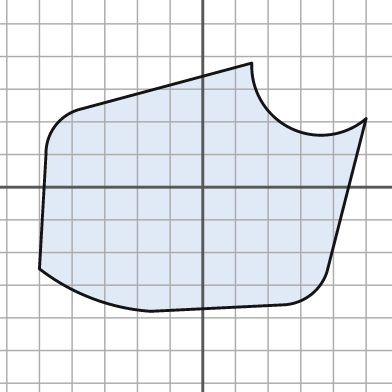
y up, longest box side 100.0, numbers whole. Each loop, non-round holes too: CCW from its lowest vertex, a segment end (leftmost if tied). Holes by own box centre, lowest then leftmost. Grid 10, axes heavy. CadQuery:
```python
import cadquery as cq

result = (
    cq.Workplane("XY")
    .moveTo(-16.0, -38.0)
    .lineTo(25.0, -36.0)
    .threePointArc((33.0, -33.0), (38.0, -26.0))
    .lineTo(50.0, 21.0)
    .threePointArc((27.0, 18.0), (15.0, 38.0))
    .lineTo(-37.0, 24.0)
    .threePointArc((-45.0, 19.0), (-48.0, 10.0))
    .lineTo(-50.0, -25.0)
    .threePointArc((-34.0, -34.0), (-16.0, -38.0))
    .close()
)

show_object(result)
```